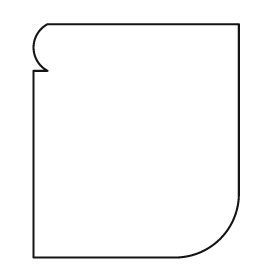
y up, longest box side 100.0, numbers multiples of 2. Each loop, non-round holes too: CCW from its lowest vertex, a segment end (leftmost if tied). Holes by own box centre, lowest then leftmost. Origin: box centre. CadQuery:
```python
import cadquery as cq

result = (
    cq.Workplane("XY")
    .moveTo(-44.0, -50.0)
    .lineTo(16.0, -50.0)
    .threePointArc((36.0, -42.0), (44.0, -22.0))
    .lineTo(44.0, 50.0)
    .lineTo(-38.0, 50.0)
    .threePointArc((-44.0, 40.0), (-38.0, 30.0))
    .lineTo(-44.0, 30.0)
    .close()
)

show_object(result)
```